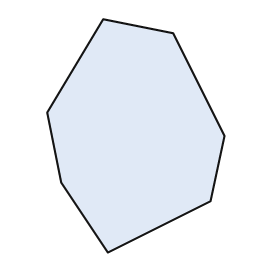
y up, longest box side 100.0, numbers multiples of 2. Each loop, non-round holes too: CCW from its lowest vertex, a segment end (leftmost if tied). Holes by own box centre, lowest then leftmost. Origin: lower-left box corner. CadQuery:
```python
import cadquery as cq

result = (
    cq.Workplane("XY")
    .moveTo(26.0, 0.0)
    .lineTo(70.0, 22.0)
    .lineTo(76.0, 50.0)
    .lineTo(54.0, 94.0)
    .lineTo(24.0, 100.0)
    .lineTo(0.0, 60.0)
    .lineTo(6.0, 30.0)
    .close()
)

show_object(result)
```